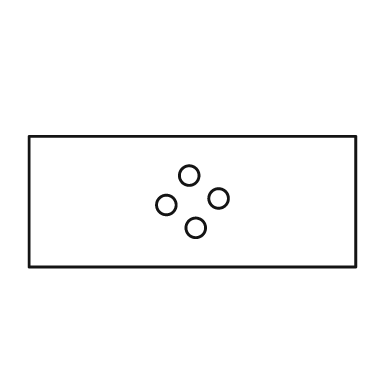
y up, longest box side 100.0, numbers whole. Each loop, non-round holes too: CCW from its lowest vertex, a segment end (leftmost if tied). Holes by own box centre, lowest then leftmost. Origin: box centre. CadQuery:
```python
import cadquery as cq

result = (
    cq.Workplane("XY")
    .moveTo(-50.0, -20.0)
    .lineTo(50.0, -20.0)
    .lineTo(50.0, 20.0)
    .lineTo(-50.0, 20.0)
    .close()
    .moveTo(1.0, -8.0)
    .circle(3.0)
    .moveTo(-8.0, -1.0)
    .circle(3.0)
    .moveTo(8.0, 1.0)
    .circle(3.0)
    .moveTo(-1.0, 8.0)
    .circle(3.0)
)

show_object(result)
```